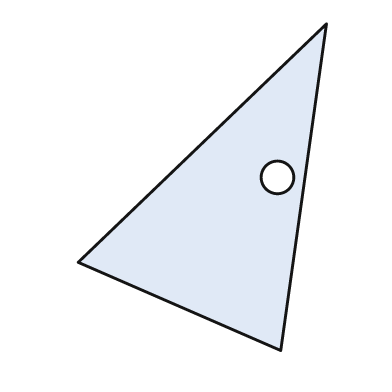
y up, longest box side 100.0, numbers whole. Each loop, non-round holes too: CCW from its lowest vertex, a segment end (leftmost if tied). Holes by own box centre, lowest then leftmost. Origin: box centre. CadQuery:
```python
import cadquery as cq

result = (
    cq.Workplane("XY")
    .moveTo(24.0, -50.0)
    .lineTo(38.0, 50.0)
    .lineTo(-38.0, -23.0)
    .close()
    .moveTo(23.0, 3.0)
    .circle(5.0)
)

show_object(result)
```